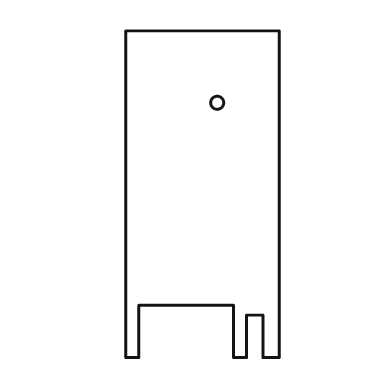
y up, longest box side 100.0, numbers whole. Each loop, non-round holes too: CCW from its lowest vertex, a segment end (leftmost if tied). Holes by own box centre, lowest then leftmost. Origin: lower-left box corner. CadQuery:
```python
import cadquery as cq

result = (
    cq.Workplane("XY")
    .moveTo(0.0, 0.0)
    .lineTo(4.0, 0.0)
    .lineTo(4.0, 16.0)
    .lineTo(33.0, 16.0)
    .lineTo(33.0, 0.0)
    .lineTo(37.0, 0.0)
    .lineTo(37.0, 13.0)
    .lineTo(42.0, 13.0)
    .lineTo(42.0, 0.0)
    .lineTo(47.0, 0.0)
    .lineTo(47.0, 100.0)
    .lineTo(0.0, 100.0)
    .close()
    .moveTo(28.0, 78.0)
    .circle(2.0)
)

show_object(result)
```